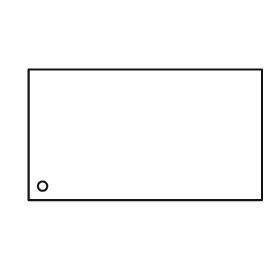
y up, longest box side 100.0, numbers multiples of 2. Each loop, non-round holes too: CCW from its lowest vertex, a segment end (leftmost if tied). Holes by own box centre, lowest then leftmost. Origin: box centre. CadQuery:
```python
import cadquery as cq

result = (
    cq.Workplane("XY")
    .moveTo(-50.0, -28.0)
    .lineTo(50.0, -28.0)
    .lineTo(50.0, 28.0)
    .lineTo(-50.0, 28.0)
    .close()
    .moveTo(-44.0, -22.0)
    .circle(2.0)
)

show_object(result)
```